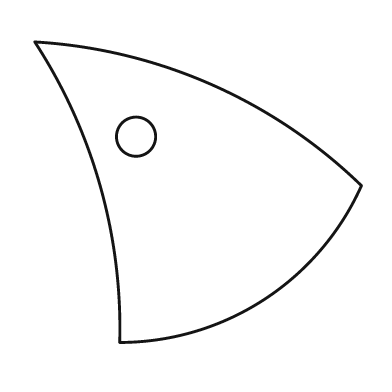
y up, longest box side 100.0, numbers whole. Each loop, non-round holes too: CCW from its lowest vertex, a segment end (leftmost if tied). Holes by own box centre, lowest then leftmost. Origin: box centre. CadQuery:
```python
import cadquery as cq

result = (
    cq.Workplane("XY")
    .moveTo(-24.0, -46.0)
    .threePointArc((20.0, -33.0), (50.0, 2.0))
    .threePointArc((4.0, 33.0), (-50.0, 46.0))
    .threePointArc((-30.0, 2.0), (-24.0, -46.0))
    .close()
    .moveTo(-19.0, 17.0)
    .circle(6.0)
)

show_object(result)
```